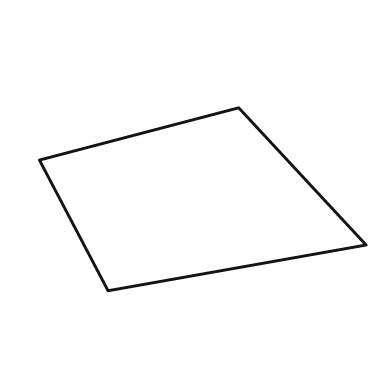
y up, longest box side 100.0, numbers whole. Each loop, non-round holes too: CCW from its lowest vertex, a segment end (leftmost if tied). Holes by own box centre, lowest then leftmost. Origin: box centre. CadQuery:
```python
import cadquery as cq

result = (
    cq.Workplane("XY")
    .moveTo(-29.0, -28.0)
    .lineTo(50.0, -14.0)
    .lineTo(11.0, 28.0)
    .lineTo(-50.0, 12.0)
    .close()
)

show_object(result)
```